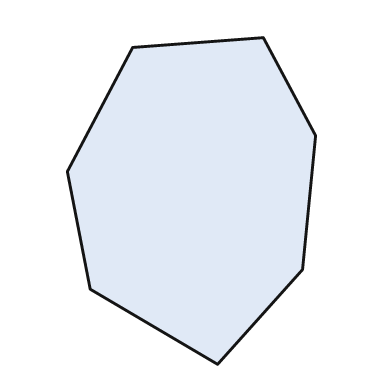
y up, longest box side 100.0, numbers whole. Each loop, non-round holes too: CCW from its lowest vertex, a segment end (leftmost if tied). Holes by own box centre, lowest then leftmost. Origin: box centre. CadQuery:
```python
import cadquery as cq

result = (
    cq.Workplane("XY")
    .moveTo(8.0, -50.0)
    .lineTo(34.0, -21.0)
    .lineTo(38.0, 20.0)
    .lineTo(22.0, 50.0)
    .lineTo(-18.0, 47.0)
    .lineTo(-38.0, 9.0)
    .lineTo(-31.0, -27.0)
    .close()
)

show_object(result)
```